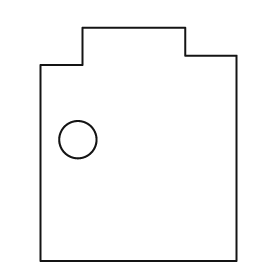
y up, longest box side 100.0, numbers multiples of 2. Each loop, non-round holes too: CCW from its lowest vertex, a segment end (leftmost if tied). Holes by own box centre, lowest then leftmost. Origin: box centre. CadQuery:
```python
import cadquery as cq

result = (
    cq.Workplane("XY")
    .moveTo(-42.0, -50.0)
    .lineTo(42.0, -50.0)
    .lineTo(42.0, 38.0)
    .lineTo(20.0, 38.0)
    .lineTo(20.0, 50.0)
    .lineTo(-24.0, 50.0)
    .lineTo(-24.0, 34.0)
    .lineTo(-42.0, 34.0)
    .close()
    .moveTo(-26.0, 2.0)
    .circle(8.0)
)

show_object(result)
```